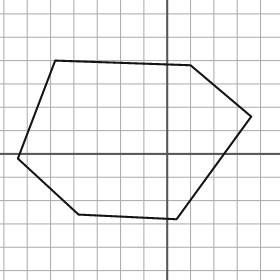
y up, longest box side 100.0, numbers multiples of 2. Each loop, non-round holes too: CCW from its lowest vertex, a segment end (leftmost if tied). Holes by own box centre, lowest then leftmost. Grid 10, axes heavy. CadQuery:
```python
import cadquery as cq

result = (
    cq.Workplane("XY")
    .moveTo(4.0, -28.0)
    .lineTo(36.0, 16.0)
    .lineTo(10.0, 38.0)
    .lineTo(-48.0, 40.0)
    .lineTo(-64.0, -2.0)
    .lineTo(-38.0, -26.0)
    .close()
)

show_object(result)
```